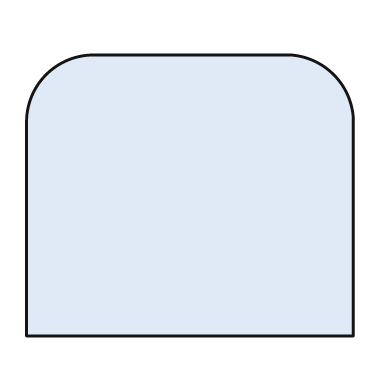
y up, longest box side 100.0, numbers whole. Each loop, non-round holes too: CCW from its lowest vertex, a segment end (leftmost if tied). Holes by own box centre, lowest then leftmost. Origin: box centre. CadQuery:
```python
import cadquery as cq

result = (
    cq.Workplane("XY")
    .moveTo(-50.0, -43.0)
    .lineTo(50.0, -43.0)
    .lineTo(50.0, 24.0)
    .threePointArc((44.0, 37.0), (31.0, 43.0))
    .lineTo(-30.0, 43.0)
    .threePointArc((-44.0, 37.0), (-50.0, 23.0))
    .close()
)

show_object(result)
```